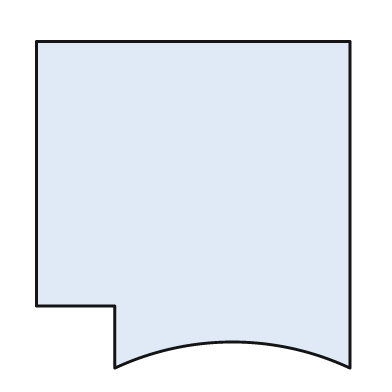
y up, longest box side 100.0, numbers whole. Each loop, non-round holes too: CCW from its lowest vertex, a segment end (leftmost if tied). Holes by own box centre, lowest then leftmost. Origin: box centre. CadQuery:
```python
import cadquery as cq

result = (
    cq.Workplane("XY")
    .moveTo(-24.0, -50.0)
    .threePointArc((12.0, -42.0), (48.0, -50.0))
    .lineTo(48.0, 50.0)
    .lineTo(-48.0, 50.0)
    .lineTo(-48.0, -31.0)
    .lineTo(-24.0, -31.0)
    .close()
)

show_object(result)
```